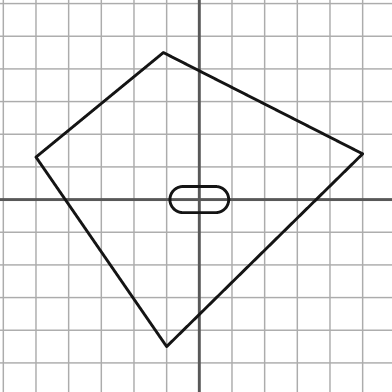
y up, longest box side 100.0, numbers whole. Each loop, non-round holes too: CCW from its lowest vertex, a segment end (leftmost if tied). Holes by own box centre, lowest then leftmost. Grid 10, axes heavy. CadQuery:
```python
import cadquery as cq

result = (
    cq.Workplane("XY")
    .moveTo(-10.0, -45.0)
    .lineTo(50.0, 14.0)
    .lineTo(-11.0, 45.0)
    .lineTo(-50.0, 13.0)
    .close()
    .moveTo(-5.0, -4.0)
    .lineTo(5.0, -4.0)
    .threePointArc((9.0, 0.0), (5.0, 4.0))
    .lineTo(-5.0, 4.0)
    .threePointArc((-9.0, 0.0), (-5.0, -4.0))
    .close()
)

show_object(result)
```